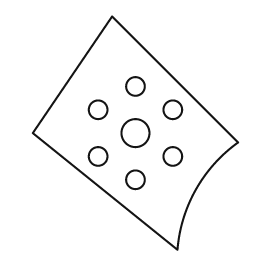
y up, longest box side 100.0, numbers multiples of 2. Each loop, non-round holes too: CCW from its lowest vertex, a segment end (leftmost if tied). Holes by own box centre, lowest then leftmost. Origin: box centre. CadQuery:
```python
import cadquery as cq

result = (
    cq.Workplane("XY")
    .moveTo(18.0, -50.0)
    .threePointArc((26.0, -24.0), (44.0, -4.0))
    .lineTo(-10.0, 50.0)
    .lineTo(-44.0, 0.0)
    .close()
    .moveTo(0.0, -20.0)
    .circle(4.0)
    .moveTo(-16.0, -10.0)
    .circle(4.0)
    .moveTo(16.0, -10.0)
    .circle(4.0)
    .moveTo(0.0, 0.0)
    .circle(6.0)
    .moveTo(-16.0, 10.0)
    .circle(4.0)
    .moveTo(16.0, 10.0)
    .circle(4.0)
    .moveTo(0.0, 20.0)
    .circle(4.0)
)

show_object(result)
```